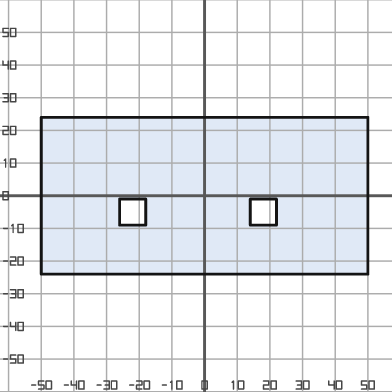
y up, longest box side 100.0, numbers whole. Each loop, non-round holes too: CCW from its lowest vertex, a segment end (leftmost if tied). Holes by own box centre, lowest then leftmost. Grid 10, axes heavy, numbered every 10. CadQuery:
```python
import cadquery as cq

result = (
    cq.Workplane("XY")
    .moveTo(-50.0, -24.0)
    .lineTo(50.0, -24.0)
    .lineTo(50.0, 24.0)
    .lineTo(-50.0, 24.0)
    .close()
    .moveTo(-26.0, -9.0)
    .lineTo(-18.0, -9.0)
    .lineTo(-18.0, -1.0)
    .lineTo(-26.0, -1.0)
    .close()
    .moveTo(14.0, -9.0)
    .lineTo(22.0, -9.0)
    .lineTo(22.0, -1.0)
    .lineTo(14.0, -1.0)
    .close()
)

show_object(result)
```